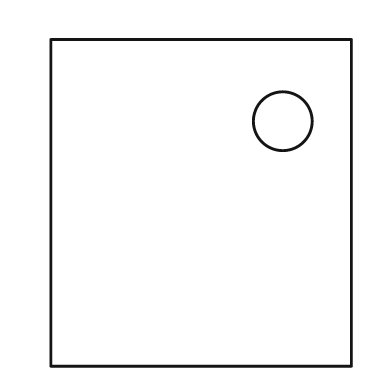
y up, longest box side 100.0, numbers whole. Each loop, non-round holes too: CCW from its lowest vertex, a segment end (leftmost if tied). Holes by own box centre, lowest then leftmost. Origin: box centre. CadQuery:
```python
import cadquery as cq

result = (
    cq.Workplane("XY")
    .moveTo(-46.0, -50.0)
    .lineTo(46.0, -50.0)
    .lineTo(46.0, 50.0)
    .lineTo(-46.0, 50.0)
    .close()
    .moveTo(25.0, 25.0)
    .circle(9.0)
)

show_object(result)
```